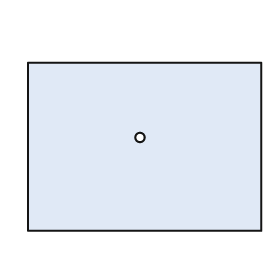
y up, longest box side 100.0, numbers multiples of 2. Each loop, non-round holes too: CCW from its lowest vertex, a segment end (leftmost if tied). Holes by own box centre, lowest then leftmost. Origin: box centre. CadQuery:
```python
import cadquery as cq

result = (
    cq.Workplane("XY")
    .moveTo(-50.0, -36.0)
    .lineTo(50.0, -36.0)
    .lineTo(50.0, 36.0)
    .lineTo(-50.0, 36.0)
    .close()
    .moveTo(-2.0, 4.0)
    .circle(2.0)
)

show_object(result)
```